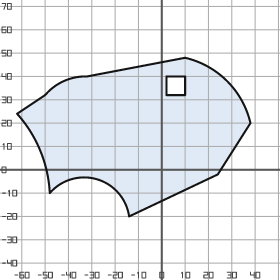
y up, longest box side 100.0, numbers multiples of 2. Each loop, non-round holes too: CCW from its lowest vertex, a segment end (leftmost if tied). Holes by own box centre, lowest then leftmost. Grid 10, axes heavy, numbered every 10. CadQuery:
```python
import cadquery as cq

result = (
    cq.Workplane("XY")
    .moveTo(-14.0, -20.0)
    .lineTo(24.0, -2.0)
    .lineTo(38.0, 20.0)
    .threePointArc((28.0, 38.0), (10.0, 48.0))
    .lineTo(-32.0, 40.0)
    .threePointArc((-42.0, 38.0), (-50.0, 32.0))
    .lineTo(-62.0, 24.0)
    .threePointArc((-52.0, 8.0), (-48.0, -10.0))
    .threePointArc((-28.0, -4.0), (-14.0, -20.0))
    .close()
    .moveTo(2.0, 32.0)
    .lineTo(10.0, 32.0)
    .lineTo(10.0, 40.0)
    .lineTo(2.0, 40.0)
    .close()
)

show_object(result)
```